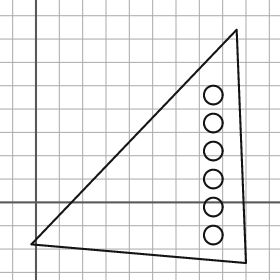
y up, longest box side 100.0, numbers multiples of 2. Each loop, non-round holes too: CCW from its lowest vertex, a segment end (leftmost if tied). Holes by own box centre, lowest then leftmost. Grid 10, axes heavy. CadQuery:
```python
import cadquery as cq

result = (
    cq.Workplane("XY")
    .moveTo(90.0, -26.0)
    .lineTo(86.0, 74.0)
    .lineTo(-2.0, -18.0)
    .close()
    .moveTo(76.0, -14.0)
    .circle(4.0)
    .moveTo(76.0, -2.0)
    .circle(4.0)
    .moveTo(76.0, 10.0)
    .circle(4.0)
    .moveTo(76.0, 22.0)
    .circle(4.0)
    .moveTo(76.0, 34.0)
    .circle(4.0)
    .moveTo(76.0, 46.0)
    .circle(4.0)
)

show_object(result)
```